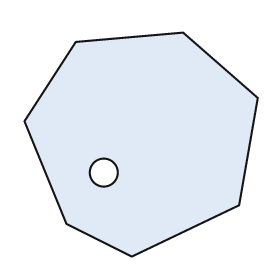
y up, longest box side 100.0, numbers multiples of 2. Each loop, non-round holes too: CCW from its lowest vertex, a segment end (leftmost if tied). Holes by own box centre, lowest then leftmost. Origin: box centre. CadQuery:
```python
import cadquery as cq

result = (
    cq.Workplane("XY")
    .moveTo(-4.0, -48.0)
    .lineTo(42.0, -26.0)
    .lineTo(50.0, 20.0)
    .lineTo(18.0, 48.0)
    .lineTo(-28.0, 44.0)
    .lineTo(-50.0, 10.0)
    .lineTo(-32.0, -34.0)
    .close()
    .moveTo(-16.0, -12.0)
    .circle(6.0)
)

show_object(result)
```